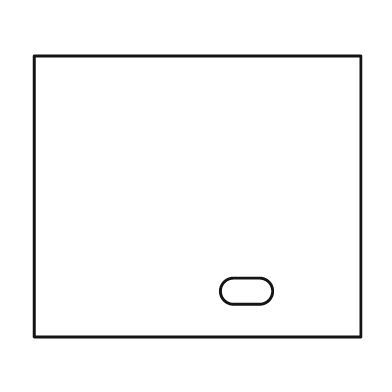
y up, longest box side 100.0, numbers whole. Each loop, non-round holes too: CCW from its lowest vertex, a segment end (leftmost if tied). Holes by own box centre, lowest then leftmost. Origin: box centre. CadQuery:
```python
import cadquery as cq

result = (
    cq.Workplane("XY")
    .moveTo(-50.0, -43.0)
    .lineTo(50.0, -43.0)
    .lineTo(50.0, 43.0)
    .lineTo(-50.0, 43.0)
    .close()
    .moveTo(11.0, -33.0)
    .lineTo(19.0, -33.0)
    .threePointArc((23.0, -29.0), (19.0, -25.0))
    .lineTo(11.0, -25.0)
    .threePointArc((7.0, -29.0), (11.0, -33.0))
    .close()
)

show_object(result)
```